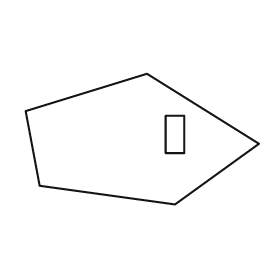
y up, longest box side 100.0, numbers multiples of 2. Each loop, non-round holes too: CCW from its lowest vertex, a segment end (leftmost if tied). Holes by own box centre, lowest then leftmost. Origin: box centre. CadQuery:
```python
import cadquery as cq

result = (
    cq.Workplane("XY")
    .moveTo(14.0, -28.0)
    .lineTo(50.0, -2.0)
    .lineTo(2.0, 28.0)
    .lineTo(-50.0, 12.0)
    .lineTo(-44.0, -20.0)
    .close()
    .moveTo(10.0, -6.0)
    .lineTo(18.0, -6.0)
    .lineTo(18.0, 10.0)
    .lineTo(10.0, 10.0)
    .close()
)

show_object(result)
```